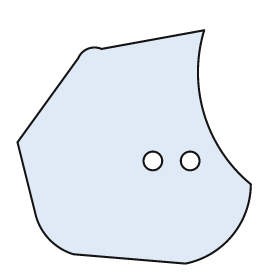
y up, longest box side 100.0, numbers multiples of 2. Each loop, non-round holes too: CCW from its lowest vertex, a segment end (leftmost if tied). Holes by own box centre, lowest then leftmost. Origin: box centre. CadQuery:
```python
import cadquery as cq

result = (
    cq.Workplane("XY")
    .moveTo(22.0, -50.0)
    .threePointArc((42.0, -38.0), (50.0, -16.0))
    .threePointArc((30.0, 14.0), (30.0, 50.0))
    .lineTo(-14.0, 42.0)
    .threePointArc((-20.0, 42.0), (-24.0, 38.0))
    .lineTo(-50.0, 2.0)
    .lineTo(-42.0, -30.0)
    .threePointArc((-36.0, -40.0), (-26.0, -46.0))
    .close()
    .moveTo(8.0, -6.0)
    .circle(4.0)
    .moveTo(24.0, -6.0)
    .circle(4.0)
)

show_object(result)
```